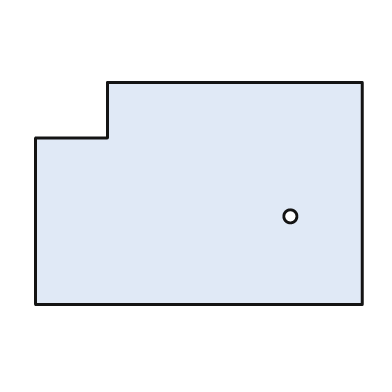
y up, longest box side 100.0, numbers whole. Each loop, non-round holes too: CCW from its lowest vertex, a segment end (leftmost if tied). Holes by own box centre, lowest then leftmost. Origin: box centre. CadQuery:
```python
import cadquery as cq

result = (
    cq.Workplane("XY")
    .moveTo(-50.0, -34.0)
    .lineTo(50.0, -34.0)
    .lineTo(50.0, 34.0)
    .lineTo(-28.0, 34.0)
    .lineTo(-28.0, 17.0)
    .lineTo(-50.0, 17.0)
    .close()
    .moveTo(28.0, -7.0)
    .circle(2.0)
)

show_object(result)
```